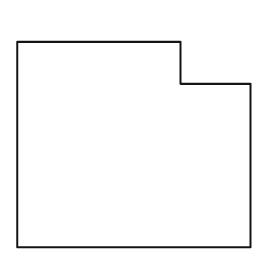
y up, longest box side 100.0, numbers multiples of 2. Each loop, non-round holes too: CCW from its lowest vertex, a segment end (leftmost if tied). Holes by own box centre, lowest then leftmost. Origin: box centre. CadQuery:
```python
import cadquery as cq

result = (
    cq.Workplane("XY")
    .moveTo(-50.0, -44.0)
    .lineTo(50.0, -44.0)
    .lineTo(50.0, 26.0)
    .lineTo(20.0, 26.0)
    .lineTo(20.0, 44.0)
    .lineTo(-50.0, 44.0)
    .close()
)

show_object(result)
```